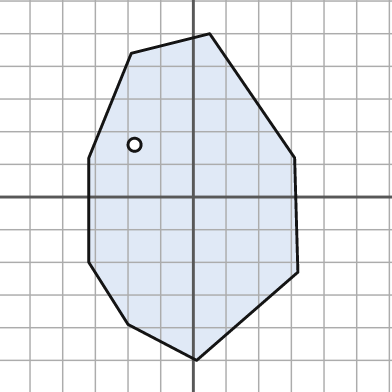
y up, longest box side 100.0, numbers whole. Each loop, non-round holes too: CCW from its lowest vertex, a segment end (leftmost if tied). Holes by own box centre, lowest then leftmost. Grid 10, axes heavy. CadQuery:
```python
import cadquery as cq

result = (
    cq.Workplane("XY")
    .moveTo(1.0, -50.0)
    .lineTo(32.0, -23.0)
    .lineTo(31.0, 12.0)
    .lineTo(5.0, 50.0)
    .lineTo(-19.0, 44.0)
    .lineTo(-32.0, 12.0)
    .lineTo(-32.0, -20.0)
    .lineTo(-20.0, -39.0)
    .close()
    .moveTo(-18.0, 16.0)
    .circle(2.0)
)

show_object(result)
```